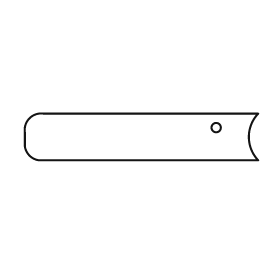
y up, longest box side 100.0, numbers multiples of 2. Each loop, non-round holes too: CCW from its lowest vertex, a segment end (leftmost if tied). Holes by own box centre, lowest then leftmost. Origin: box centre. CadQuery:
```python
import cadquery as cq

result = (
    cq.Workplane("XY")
    .moveTo(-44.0, -10.0)
    .lineTo(50.0, -10.0)
    .threePointArc((46.0, 0.0), (50.0, 10.0))
    .lineTo(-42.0, 10.0)
    .threePointArc((-48.0, 8.0), (-50.0, 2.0))
    .lineTo(-50.0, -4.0)
    .threePointArc((-48.0, -8.0), (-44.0, -10.0))
    .close()
    .moveTo(32.0, 4.0)
    .circle(2.0)
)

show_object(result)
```